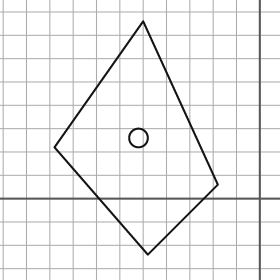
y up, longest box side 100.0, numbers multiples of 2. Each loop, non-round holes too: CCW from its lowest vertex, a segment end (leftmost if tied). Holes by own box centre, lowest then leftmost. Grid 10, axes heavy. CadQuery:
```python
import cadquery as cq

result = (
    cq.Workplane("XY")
    .moveTo(-48.0, -24.0)
    .lineTo(-18.0, 6.0)
    .lineTo(-50.0, 76.0)
    .lineTo(-88.0, 22.0)
    .close()
    .moveTo(-52.0, 26.0)
    .circle(4.0)
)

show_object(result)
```